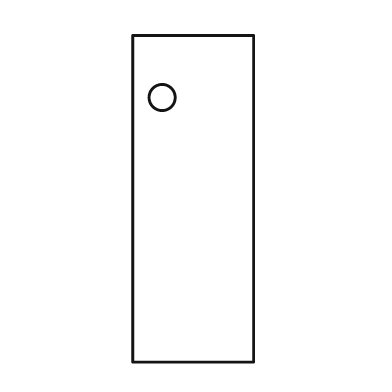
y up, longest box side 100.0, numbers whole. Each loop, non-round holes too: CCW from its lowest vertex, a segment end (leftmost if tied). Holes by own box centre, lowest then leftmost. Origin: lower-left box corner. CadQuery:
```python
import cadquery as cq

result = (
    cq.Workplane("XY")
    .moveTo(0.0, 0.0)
    .lineTo(37.0, 0.0)
    .lineTo(37.0, 100.0)
    .lineTo(0.0, 100.0)
    .close()
    .moveTo(9.0, 81.0)
    .circle(4.0)
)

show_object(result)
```